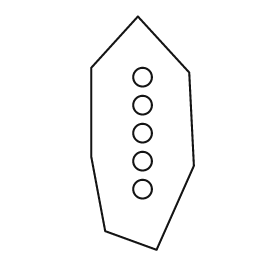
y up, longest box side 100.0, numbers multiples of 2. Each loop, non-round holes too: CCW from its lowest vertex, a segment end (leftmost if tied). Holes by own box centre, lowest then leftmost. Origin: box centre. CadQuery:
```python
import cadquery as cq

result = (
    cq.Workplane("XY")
    .moveTo(6.0, -50.0)
    .lineTo(22.0, -14.0)
    .lineTo(20.0, 26.0)
    .lineTo(-2.0, 50.0)
    .lineTo(-22.0, 28.0)
    .lineTo(-22.0, -10.0)
    .lineTo(-16.0, -42.0)
    .close()
    .moveTo(0.0, -24.0)
    .circle(4.0)
    .moveTo(0.0, -12.0)
    .circle(4.0)
    .moveTo(0.0, 0.0)
    .circle(4.0)
    .moveTo(0.0, 12.0)
    .circle(4.0)
    .moveTo(0.0, 24.0)
    .circle(4.0)
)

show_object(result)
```